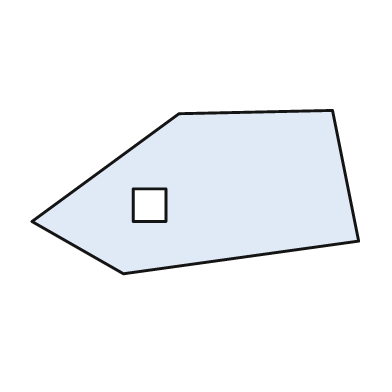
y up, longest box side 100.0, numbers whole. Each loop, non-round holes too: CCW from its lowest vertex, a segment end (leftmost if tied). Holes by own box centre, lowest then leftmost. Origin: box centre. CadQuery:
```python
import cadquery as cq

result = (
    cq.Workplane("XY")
    .moveTo(-22.0, -25.0)
    .lineTo(50.0, -15.0)
    .lineTo(42.0, 25.0)
    .lineTo(-5.0, 24.0)
    .lineTo(-50.0, -9.0)
    .close()
    .moveTo(-19.0, -9.0)
    .lineTo(-9.0, -9.0)
    .lineTo(-9.0, 1.0)
    .lineTo(-19.0, 1.0)
    .close()
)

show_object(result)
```